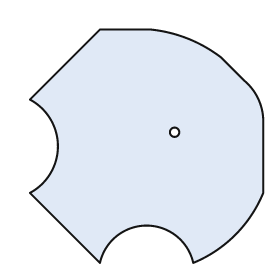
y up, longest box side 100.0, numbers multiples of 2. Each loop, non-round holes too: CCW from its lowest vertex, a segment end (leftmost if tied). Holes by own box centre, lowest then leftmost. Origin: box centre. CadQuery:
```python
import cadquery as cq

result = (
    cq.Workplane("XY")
    .moveTo(-20.0, -50.0)
    .threePointArc((0.0, -34.0), (20.0, -50.0))
    .threePointArc((38.0, -38.0), (50.0, -20.0))
    .lineTo(50.0, 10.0)
    .threePointArc((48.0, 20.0), (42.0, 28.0))
    .lineTo(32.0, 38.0)
    .threePointArc((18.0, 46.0), (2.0, 50.0))
    .lineTo(-20.0, 50.0)
    .lineTo(-50.0, 20.0)
    .threePointArc((-38.0, 0.0), (-50.0, -20.0))
    .close()
    .moveTo(12.0, 6.0)
    .circle(2.0)
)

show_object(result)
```